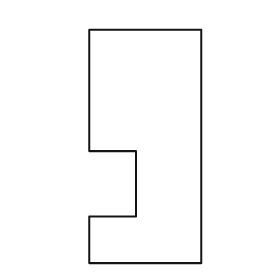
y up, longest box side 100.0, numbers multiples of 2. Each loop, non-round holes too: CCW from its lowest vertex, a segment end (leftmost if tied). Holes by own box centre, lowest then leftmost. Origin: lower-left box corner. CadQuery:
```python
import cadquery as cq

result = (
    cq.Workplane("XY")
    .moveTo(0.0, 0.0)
    .lineTo(48.0, 0.0)
    .lineTo(48.0, 100.0)
    .lineTo(0.0, 100.0)
    .lineTo(0.0, 48.0)
    .lineTo(20.0, 48.0)
    .lineTo(20.0, 20.0)
    .lineTo(0.0, 20.0)
    .close()
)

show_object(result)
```